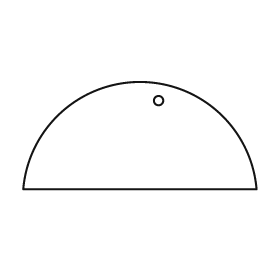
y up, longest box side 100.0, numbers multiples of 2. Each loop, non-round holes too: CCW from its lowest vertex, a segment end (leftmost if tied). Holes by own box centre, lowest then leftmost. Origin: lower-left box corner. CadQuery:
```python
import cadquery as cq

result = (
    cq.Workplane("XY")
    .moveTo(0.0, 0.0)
    .lineTo(100.0, 0.0)
    .threePointArc((50.0, 46.0), (0.0, 0.0))
    .close()
    .moveTo(58.0, 38.0)
    .circle(2.0)
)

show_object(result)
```